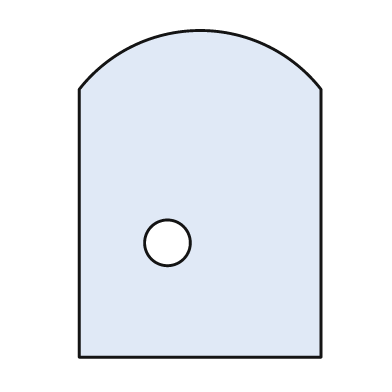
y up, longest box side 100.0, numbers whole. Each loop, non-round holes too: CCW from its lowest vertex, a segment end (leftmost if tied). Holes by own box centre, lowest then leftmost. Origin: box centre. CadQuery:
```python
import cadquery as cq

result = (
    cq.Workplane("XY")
    .moveTo(-37.0, -50.0)
    .lineTo(37.0, -50.0)
    .lineTo(37.0, 32.0)
    .threePointArc((0.0, 50.0), (-37.0, 32.0))
    .close()
    .moveTo(-10.0, -15.0)
    .circle(7.0)
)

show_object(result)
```